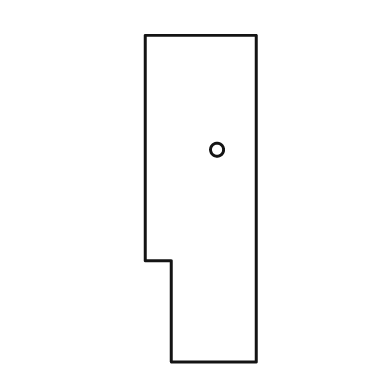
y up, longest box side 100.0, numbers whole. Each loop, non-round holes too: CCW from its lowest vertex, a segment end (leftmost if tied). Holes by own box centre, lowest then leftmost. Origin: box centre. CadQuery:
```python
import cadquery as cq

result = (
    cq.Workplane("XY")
    .moveTo(-9.0, -50.0)
    .lineTo(17.0, -50.0)
    .lineTo(17.0, 50.0)
    .lineTo(-17.0, 50.0)
    .lineTo(-17.0, -19.0)
    .lineTo(-9.0, -19.0)
    .close()
    .moveTo(5.0, 15.0)
    .circle(2.0)
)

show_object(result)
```